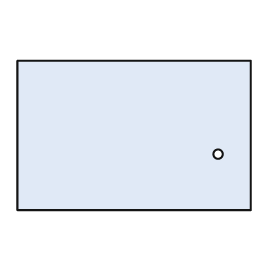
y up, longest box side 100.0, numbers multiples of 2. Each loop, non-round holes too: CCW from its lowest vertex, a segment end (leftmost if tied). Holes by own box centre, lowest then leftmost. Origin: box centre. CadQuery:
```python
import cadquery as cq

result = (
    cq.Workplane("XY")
    .moveTo(-50.0, -32.0)
    .lineTo(50.0, -32.0)
    .lineTo(50.0, 32.0)
    .lineTo(-50.0, 32.0)
    .close()
    .moveTo(36.0, -8.0)
    .circle(2.0)
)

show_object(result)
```